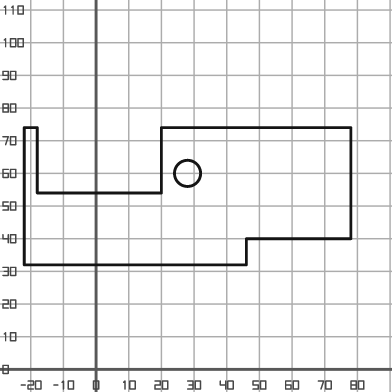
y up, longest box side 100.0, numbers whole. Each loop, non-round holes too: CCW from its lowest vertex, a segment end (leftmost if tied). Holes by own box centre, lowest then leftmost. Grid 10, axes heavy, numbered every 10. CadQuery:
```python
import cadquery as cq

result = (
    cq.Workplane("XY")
    .moveTo(-22.0, 32.0)
    .lineTo(46.0, 32.0)
    .lineTo(46.0, 40.0)
    .lineTo(78.0, 40.0)
    .lineTo(78.0, 74.0)
    .lineTo(20.0, 74.0)
    .lineTo(20.0, 54.0)
    .lineTo(-18.0, 54.0)
    .lineTo(-18.0, 74.0)
    .lineTo(-22.0, 74.0)
    .close()
    .moveTo(28.0, 60.0)
    .circle(4.0)
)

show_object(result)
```